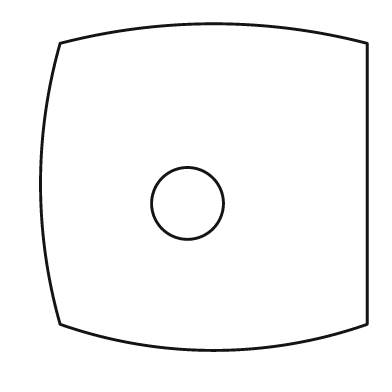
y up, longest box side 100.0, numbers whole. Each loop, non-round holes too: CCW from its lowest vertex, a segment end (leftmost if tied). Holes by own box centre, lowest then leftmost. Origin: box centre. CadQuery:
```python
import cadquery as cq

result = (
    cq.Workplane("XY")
    .moveTo(-44.0, -42.0)
    .threePointArc((3.0, -50.0), (50.0, -42.0))
    .lineTo(50.0, 44.0)
    .threePointArc((3.0, 50.0), (-44.0, 44.0))
    .threePointArc((-50.0, 1.0), (-44.0, -42.0))
    .close()
    .moveTo(-5.0, -5.0)
    .circle(11.0)
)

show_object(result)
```